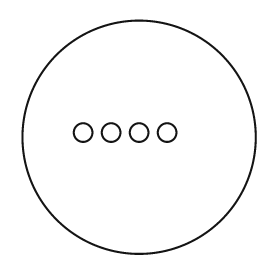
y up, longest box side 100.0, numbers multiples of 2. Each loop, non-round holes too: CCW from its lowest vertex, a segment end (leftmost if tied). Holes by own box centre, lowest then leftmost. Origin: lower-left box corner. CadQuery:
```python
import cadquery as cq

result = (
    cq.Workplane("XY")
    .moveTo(50.0, 50.0)
    .circle(50.0)
    .moveTo(26.0, 52.0)
    .circle(4.0)
    .moveTo(38.0, 52.0)
    .circle(4.0)
    .moveTo(50.0, 52.0)
    .circle(4.0)
    .moveTo(62.0, 52.0)
    .circle(4.0)
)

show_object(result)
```